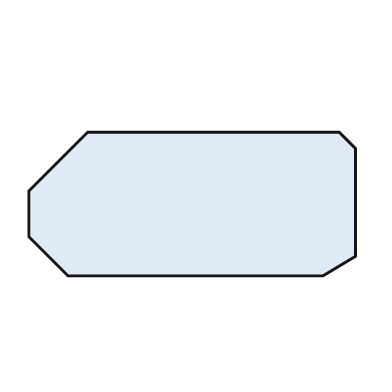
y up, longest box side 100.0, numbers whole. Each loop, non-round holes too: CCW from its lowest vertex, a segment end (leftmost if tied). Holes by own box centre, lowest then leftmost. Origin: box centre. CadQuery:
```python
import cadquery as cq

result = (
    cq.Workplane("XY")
    .moveTo(-38.0, -22.0)
    .lineTo(40.0, -22.0)
    .lineTo(50.0, -16.0)
    .lineTo(50.0, 17.0)
    .lineTo(45.0, 22.0)
    .lineTo(-32.0, 22.0)
    .lineTo(-50.0, 4.0)
    .lineTo(-50.0, -10.0)
    .close()
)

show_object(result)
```